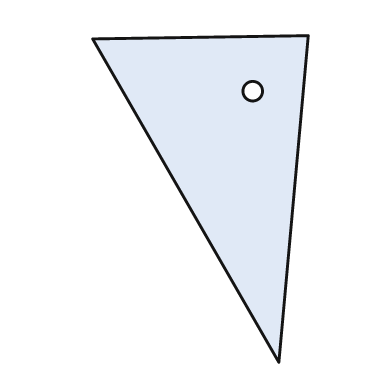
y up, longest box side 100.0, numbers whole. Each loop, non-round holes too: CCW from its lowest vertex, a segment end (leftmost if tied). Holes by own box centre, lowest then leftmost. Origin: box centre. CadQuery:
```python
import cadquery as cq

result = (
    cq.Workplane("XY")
    .moveTo(24.0, -50.0)
    .lineTo(33.0, 50.0)
    .lineTo(-33.0, 49.0)
    .close()
    .moveTo(16.0, 33.0)
    .circle(3.0)
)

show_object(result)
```